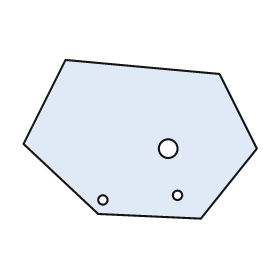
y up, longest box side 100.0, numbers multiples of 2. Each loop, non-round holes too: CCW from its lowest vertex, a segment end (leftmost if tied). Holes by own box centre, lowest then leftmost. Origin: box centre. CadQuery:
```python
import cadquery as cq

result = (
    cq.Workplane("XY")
    .moveTo(26.0, -34.0)
    .lineTo(50.0, -4.0)
    .lineTo(34.0, 28.0)
    .lineTo(-32.0, 34.0)
    .lineTo(-50.0, -2.0)
    .lineTo(-18.0, -32.0)
    .close()
    .moveTo(-16.0, -26.0)
    .circle(2.0)
    .moveTo(16.0, -24.0)
    .circle(2.0)
    .moveTo(12.0, -4.0)
    .circle(4.0)
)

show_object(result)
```